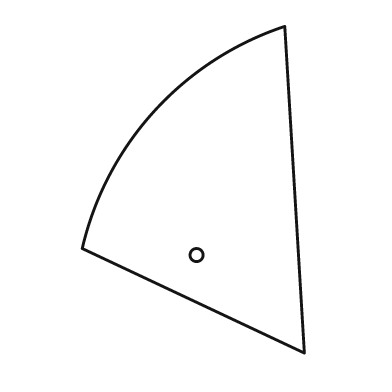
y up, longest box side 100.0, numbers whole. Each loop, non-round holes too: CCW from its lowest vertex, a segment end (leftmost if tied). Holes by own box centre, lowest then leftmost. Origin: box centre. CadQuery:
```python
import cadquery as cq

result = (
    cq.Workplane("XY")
    .moveTo(34.0, -50.0)
    .lineTo(28.0, 50.0)
    .threePointArc((-12.0, 24.0), (-34.0, -18.0))
    .close()
    .moveTo(1.0, -20.0)
    .circle(2.0)
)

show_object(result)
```